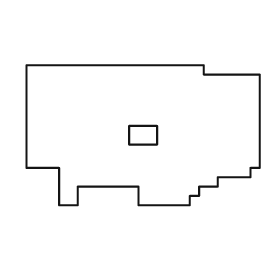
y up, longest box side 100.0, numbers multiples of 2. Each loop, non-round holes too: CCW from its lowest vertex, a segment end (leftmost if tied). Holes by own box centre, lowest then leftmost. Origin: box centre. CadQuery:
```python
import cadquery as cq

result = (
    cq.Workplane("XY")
    .moveTo(-36.0, -30.0)
    .lineTo(-28.0, -30.0)
    .lineTo(-28.0, -22.0)
    .lineTo(-2.0, -22.0)
    .lineTo(-2.0, -30.0)
    .lineTo(20.0, -30.0)
    .lineTo(20.0, -26.0)
    .lineTo(24.0, -26.0)
    .lineTo(24.0, -22.0)
    .lineTo(32.0, -22.0)
    .lineTo(32.0, -18.0)
    .lineTo(46.0, -18.0)
    .lineTo(46.0, -14.0)
    .lineTo(50.0, -14.0)
    .lineTo(50.0, 26.0)
    .lineTo(26.0, 26.0)
    .lineTo(26.0, 30.0)
    .lineTo(-50.0, 30.0)
    .lineTo(-50.0, -14.0)
    .lineTo(-36.0, -14.0)
    .close()
    .moveTo(-6.0, -4.0)
    .lineTo(6.0, -4.0)
    .lineTo(6.0, 4.0)
    .lineTo(-6.0, 4.0)
    .close()
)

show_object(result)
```